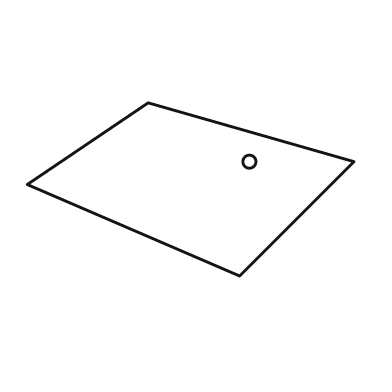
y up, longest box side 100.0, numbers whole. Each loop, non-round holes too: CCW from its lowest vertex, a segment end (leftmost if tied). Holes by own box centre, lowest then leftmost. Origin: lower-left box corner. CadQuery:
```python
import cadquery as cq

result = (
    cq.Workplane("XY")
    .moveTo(65.0, 0.0)
    .lineTo(100.0, 35.0)
    .lineTo(37.0, 53.0)
    .lineTo(0.0, 28.0)
    .close()
    .moveTo(68.0, 35.0)
    .circle(2.0)
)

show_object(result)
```